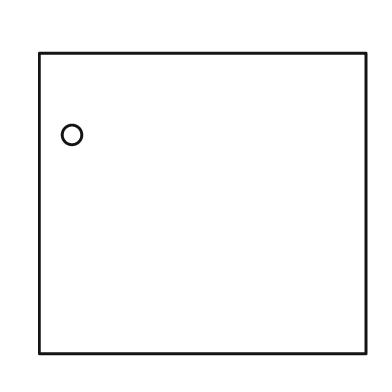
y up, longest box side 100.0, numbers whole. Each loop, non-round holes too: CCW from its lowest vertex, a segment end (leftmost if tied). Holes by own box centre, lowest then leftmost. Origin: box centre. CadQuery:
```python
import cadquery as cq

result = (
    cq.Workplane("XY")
    .moveTo(-50.0, -46.0)
    .lineTo(50.0, -46.0)
    .lineTo(50.0, 46.0)
    .lineTo(-50.0, 46.0)
    .close()
    .moveTo(-40.0, 21.0)
    .circle(3.0)
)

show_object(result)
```